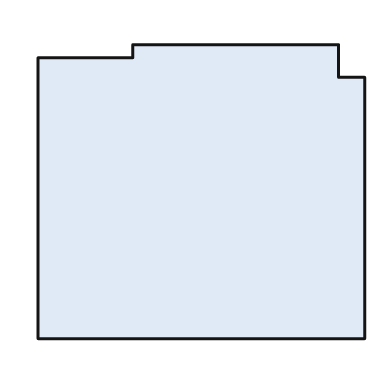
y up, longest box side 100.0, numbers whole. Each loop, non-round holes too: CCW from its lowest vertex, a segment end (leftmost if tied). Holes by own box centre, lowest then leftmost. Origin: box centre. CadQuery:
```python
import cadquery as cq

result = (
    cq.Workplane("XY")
    .moveTo(-50.0, -45.0)
    .lineTo(50.0, -45.0)
    .lineTo(50.0, 35.0)
    .lineTo(42.0, 35.0)
    .lineTo(42.0, 45.0)
    .lineTo(-21.0, 45.0)
    .lineTo(-21.0, 41.0)
    .lineTo(-50.0, 41.0)
    .close()
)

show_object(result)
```